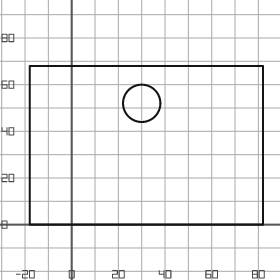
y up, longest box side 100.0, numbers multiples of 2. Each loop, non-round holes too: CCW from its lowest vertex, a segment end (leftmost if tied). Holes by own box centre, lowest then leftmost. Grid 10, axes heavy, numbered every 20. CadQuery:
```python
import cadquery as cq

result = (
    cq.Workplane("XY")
    .moveTo(-18.0, 0.0)
    .lineTo(82.0, 0.0)
    .lineTo(82.0, 68.0)
    .lineTo(-18.0, 68.0)
    .close()
    .moveTo(30.0, 52.0)
    .circle(8.0)
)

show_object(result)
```